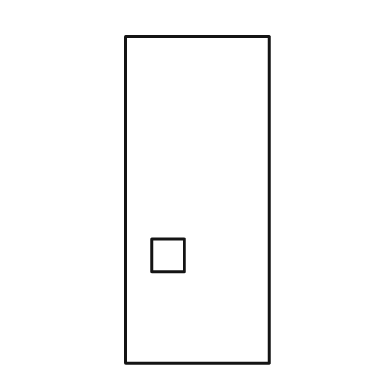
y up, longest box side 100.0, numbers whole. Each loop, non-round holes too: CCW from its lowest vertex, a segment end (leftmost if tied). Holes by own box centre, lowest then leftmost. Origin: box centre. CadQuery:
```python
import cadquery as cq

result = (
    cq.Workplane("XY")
    .moveTo(-22.0, -50.0)
    .lineTo(22.0, -50.0)
    .lineTo(22.0, 50.0)
    .lineTo(-22.0, 50.0)
    .close()
    .moveTo(-14.0, -22.0)
    .lineTo(-4.0, -22.0)
    .lineTo(-4.0, -12.0)
    .lineTo(-14.0, -12.0)
    .close()
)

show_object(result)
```